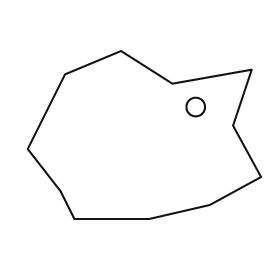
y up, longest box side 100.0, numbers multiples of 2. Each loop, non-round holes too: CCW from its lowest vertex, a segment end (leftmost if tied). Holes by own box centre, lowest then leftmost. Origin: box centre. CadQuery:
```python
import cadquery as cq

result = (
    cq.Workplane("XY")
    .moveTo(-30.0, -36.0)
    .lineTo(2.0, -36.0)
    .lineTo(28.0, -30.0)
    .lineTo(50.0, -18.0)
    .lineTo(38.0, 4.0)
    .lineTo(46.0, 28.0)
    .lineTo(12.0, 22.0)
    .lineTo(-10.0, 36.0)
    .lineTo(-34.0, 26.0)
    .lineTo(-50.0, -6.0)
    .lineTo(-36.0, -24.0)
    .close()
    .moveTo(22.0, 12.0)
    .circle(4.0)
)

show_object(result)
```